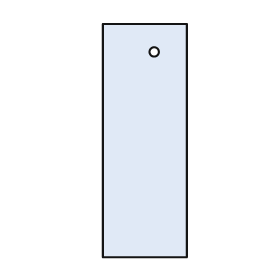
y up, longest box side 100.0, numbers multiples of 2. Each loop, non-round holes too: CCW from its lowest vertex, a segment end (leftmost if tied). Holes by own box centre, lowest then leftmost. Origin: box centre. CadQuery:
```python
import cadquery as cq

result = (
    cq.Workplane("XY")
    .moveTo(-18.0, -50.0)
    .lineTo(18.0, -50.0)
    .lineTo(18.0, 50.0)
    .lineTo(-18.0, 50.0)
    .close()
    .moveTo(4.0, 38.0)
    .circle(2.0)
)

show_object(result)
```